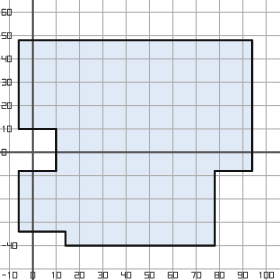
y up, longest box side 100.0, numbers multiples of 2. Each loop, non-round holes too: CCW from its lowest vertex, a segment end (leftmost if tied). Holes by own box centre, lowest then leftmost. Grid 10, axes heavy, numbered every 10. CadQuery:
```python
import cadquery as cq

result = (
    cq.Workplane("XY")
    .moveTo(14.0, -40.0)
    .lineTo(78.0, -40.0)
    .lineTo(78.0, -8.0)
    .lineTo(94.0, -8.0)
    .lineTo(94.0, 48.0)
    .lineTo(-6.0, 48.0)
    .lineTo(-6.0, 10.0)
    .lineTo(10.0, 10.0)
    .lineTo(10.0, -8.0)
    .lineTo(-6.0, -8.0)
    .lineTo(-6.0, -34.0)
    .lineTo(14.0, -34.0)
    .close()
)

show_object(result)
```